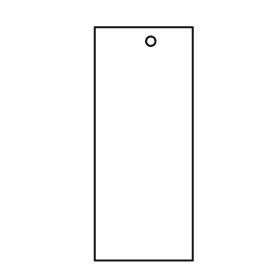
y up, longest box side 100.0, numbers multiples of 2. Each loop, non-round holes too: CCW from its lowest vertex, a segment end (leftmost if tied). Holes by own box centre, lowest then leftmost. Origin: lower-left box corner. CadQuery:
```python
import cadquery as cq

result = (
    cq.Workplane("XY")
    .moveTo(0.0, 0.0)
    .lineTo(42.0, 0.0)
    .lineTo(42.0, 100.0)
    .lineTo(0.0, 100.0)
    .close()
    .moveTo(24.0, 94.0)
    .circle(2.0)
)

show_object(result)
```